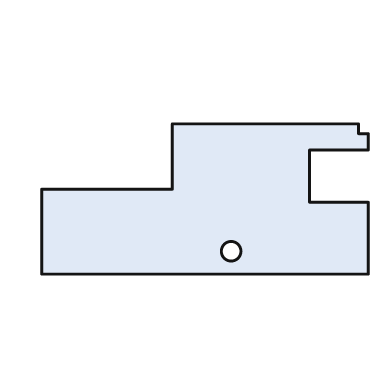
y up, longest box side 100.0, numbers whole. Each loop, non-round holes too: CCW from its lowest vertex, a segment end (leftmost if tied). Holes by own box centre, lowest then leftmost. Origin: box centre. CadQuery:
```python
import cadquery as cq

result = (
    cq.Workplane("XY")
    .moveTo(-50.0, -23.0)
    .lineTo(50.0, -23.0)
    .lineTo(50.0, -1.0)
    .lineTo(32.0, -1.0)
    .lineTo(32.0, 15.0)
    .lineTo(50.0, 15.0)
    .lineTo(50.0, 20.0)
    .lineTo(47.0, 20.0)
    .lineTo(47.0, 23.0)
    .lineTo(-10.0, 23.0)
    .lineTo(-10.0, 3.0)
    .lineTo(-50.0, 3.0)
    .close()
    .moveTo(8.0, -16.0)
    .circle(3.0)
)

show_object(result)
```